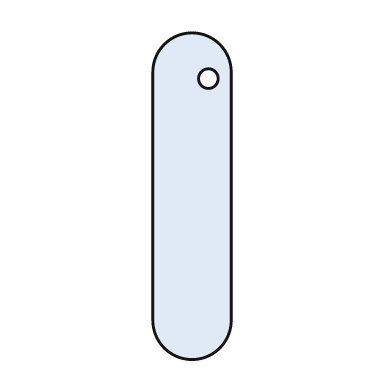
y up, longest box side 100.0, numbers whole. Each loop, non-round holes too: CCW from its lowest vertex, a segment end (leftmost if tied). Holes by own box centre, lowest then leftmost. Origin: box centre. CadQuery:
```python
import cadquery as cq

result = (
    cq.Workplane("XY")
    .moveTo(-12.0, -38.0)
    .threePointArc((0.0, -50.0), (12.0, -38.0))
    .lineTo(12.0, 38.0)
    .threePointArc((0.0, 50.0), (-12.0, 38.0))
    .close()
    .moveTo(5.0, 36.0)
    .circle(3.0)
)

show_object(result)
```